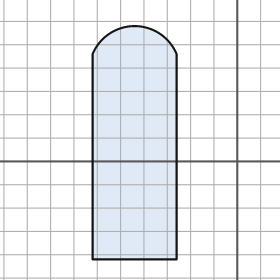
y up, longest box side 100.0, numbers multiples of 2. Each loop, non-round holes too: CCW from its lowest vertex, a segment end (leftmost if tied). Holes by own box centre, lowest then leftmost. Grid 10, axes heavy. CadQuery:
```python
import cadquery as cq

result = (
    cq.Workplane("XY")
    .moveTo(-62.0, -42.0)
    .lineTo(-26.0, -42.0)
    .lineTo(-26.0, 46.0)
    .threePointArc((-44.0, 58.0), (-62.0, 46.0))
    .close()
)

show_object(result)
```